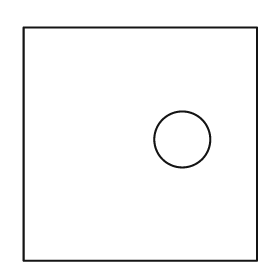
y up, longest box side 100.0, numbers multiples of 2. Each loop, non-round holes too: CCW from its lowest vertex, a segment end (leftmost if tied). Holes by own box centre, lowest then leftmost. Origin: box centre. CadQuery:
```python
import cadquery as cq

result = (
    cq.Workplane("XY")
    .moveTo(-50.0, -50.0)
    .lineTo(50.0, -50.0)
    .lineTo(50.0, 50.0)
    .lineTo(-50.0, 50.0)
    .close()
    .moveTo(18.0, 2.0)
    .circle(12.0)
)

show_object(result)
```